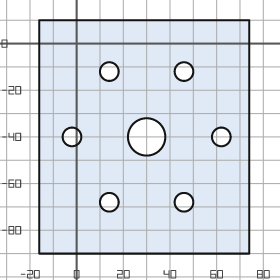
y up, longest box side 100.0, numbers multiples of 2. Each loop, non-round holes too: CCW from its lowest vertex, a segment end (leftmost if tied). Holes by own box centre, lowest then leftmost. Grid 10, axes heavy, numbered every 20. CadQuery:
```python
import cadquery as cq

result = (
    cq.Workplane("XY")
    .moveTo(-16.0, -90.0)
    .lineTo(74.0, -90.0)
    .lineTo(74.0, 10.0)
    .lineTo(-16.0, 10.0)
    .close()
    .moveTo(14.0, -68.0)
    .circle(4.0)
    .moveTo(46.0, -68.0)
    .circle(4.0)
    .moveTo(-2.0, -40.0)
    .circle(4.0)
    .moveTo(30.0, -40.0)
    .circle(8.0)
    .moveTo(62.0, -40.0)
    .circle(4.0)
    .moveTo(14.0, -12.0)
    .circle(4.0)
    .moveTo(46.0, -12.0)
    .circle(4.0)
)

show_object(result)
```